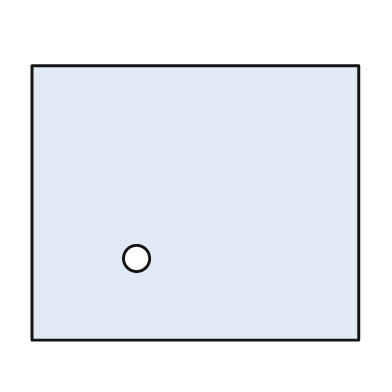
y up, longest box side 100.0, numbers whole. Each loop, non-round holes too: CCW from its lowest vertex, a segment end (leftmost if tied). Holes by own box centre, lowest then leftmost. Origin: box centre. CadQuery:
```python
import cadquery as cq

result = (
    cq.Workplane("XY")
    .moveTo(-50.0, -42.0)
    .lineTo(50.0, -42.0)
    .lineTo(50.0, 42.0)
    .lineTo(-50.0, 42.0)
    .close()
    .moveTo(-18.0, -17.0)
    .circle(4.0)
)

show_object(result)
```